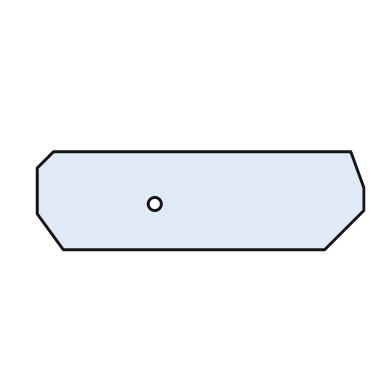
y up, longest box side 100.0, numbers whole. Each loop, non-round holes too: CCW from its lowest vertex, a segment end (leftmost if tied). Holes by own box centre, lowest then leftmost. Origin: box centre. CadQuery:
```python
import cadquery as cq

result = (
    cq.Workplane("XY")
    .moveTo(-42.0, -15.0)
    .lineTo(38.0, -15.0)
    .lineTo(50.0, -3.0)
    .lineTo(50.0, 4.0)
    .lineTo(46.0, 15.0)
    .lineTo(-45.0, 15.0)
    .lineTo(-50.0, 10.0)
    .lineTo(-50.0, -4.0)
    .close()
    .moveTo(-14.0, -1.0)
    .circle(2.0)
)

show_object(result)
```